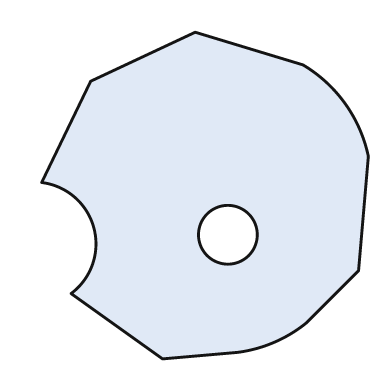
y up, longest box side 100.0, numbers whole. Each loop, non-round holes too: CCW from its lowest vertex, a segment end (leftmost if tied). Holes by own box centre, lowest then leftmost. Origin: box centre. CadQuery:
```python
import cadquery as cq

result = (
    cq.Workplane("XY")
    .moveTo(-13.0, -50.0)
    .lineTo(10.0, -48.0)
    .threePointArc((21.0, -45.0), (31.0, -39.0))
    .lineTo(47.0, -23.0)
    .lineTo(50.0, 12.0)
    .threePointArc((43.0, 28.0), (30.0, 40.0))
    .lineTo(-3.0, 50.0)
    .lineTo(-35.0, 35.0)
    .lineTo(-50.0, 4.0)
    .threePointArc((-34.0, -10.0), (-41.0, -30.0))
    .close()
    .moveTo(7.0, -12.0)
    .circle(9.0)
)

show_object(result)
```